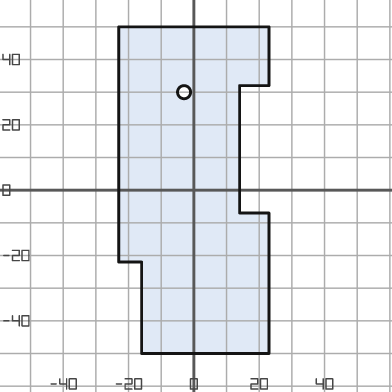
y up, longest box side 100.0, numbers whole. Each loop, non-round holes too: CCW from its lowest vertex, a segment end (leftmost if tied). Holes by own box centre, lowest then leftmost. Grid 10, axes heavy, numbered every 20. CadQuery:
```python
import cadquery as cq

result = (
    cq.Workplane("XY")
    .moveTo(-16.0, -50.0)
    .lineTo(23.0, -50.0)
    .lineTo(23.0, -7.0)
    .lineTo(14.0, -7.0)
    .lineTo(14.0, 32.0)
    .lineTo(23.0, 32.0)
    .lineTo(23.0, 50.0)
    .lineTo(-23.0, 50.0)
    .lineTo(-23.0, -22.0)
    .lineTo(-16.0, -22.0)
    .close()
    .moveTo(-3.0, 30.0)
    .circle(2.0)
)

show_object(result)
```